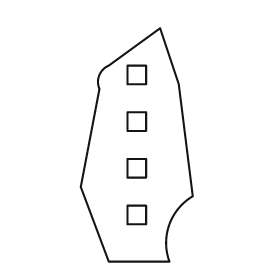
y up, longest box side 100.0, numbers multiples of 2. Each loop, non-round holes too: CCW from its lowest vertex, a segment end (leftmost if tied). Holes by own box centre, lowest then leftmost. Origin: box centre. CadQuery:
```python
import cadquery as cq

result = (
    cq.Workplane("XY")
    .moveTo(-12.0, -50.0)
    .lineTo(14.0, -50.0)
    .threePointArc((14.0, -34.0), (24.0, -22.0))
    .lineTo(18.0, 26.0)
    .lineTo(10.0, 50.0)
    .lineTo(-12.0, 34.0)
    .threePointArc((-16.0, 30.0), (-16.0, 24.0))
    .lineTo(-24.0, -18.0)
    .close()
    .moveTo(-4.0, -34.0)
    .lineTo(4.0, -34.0)
    .lineTo(4.0, -26.0)
    .lineTo(-4.0, -26.0)
    .close()
    .moveTo(-4.0, -14.0)
    .lineTo(4.0, -14.0)
    .lineTo(4.0, -6.0)
    .lineTo(-4.0, -6.0)
    .close()
    .moveTo(-4.0, 6.0)
    .lineTo(4.0, 6.0)
    .lineTo(4.0, 14.0)
    .lineTo(-4.0, 14.0)
    .close()
    .moveTo(-4.0, 26.0)
    .lineTo(4.0, 26.0)
    .lineTo(4.0, 34.0)
    .lineTo(-4.0, 34.0)
    .close()
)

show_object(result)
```